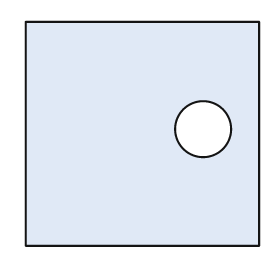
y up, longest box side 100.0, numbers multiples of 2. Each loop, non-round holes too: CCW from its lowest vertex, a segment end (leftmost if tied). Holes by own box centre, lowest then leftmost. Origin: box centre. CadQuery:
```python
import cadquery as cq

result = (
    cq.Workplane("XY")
    .moveTo(-50.0, -48.0)
    .lineTo(50.0, -48.0)
    .lineTo(50.0, 48.0)
    .lineTo(-50.0, 48.0)
    .close()
    .moveTo(26.0, 2.0)
    .circle(12.0)
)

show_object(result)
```